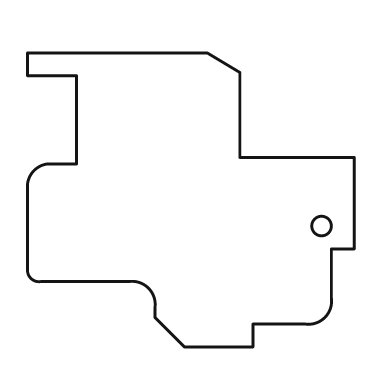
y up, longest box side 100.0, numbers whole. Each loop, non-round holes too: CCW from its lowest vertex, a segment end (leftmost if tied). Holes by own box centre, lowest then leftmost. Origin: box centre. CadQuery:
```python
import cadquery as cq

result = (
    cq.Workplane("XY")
    .moveTo(-2.0, -45.0)
    .lineTo(19.0, -45.0)
    .lineTo(19.0, -38.0)
    .lineTo(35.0, -38.0)
    .threePointArc((41.0, -36.0), (43.0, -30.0))
    .lineTo(43.0, -15.0)
    .lineTo(50.0, -15.0)
    .lineTo(50.0, 13.0)
    .lineTo(15.0, 13.0)
    .lineTo(15.0, 39.0)
    .lineTo(5.0, 45.0)
    .lineTo(-50.0, 45.0)
    .lineTo(-50.0, 38.0)
    .lineTo(-35.0, 38.0)
    .lineTo(-35.0, 11.0)
    .lineTo(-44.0, 11.0)
    .threePointArc((-48.0, 9.0), (-50.0, 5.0))
    .lineTo(-50.0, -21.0)
    .threePointArc((-49.0, -24.0), (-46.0, -25.0))
    .lineTo(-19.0, -25.0)
    .threePointArc((-13.0, -27.0), (-11.0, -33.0))
    .lineTo(-11.0, -36.0)
    .close()
    .moveTo(40.0, -8.0)
    .circle(3.0)
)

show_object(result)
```